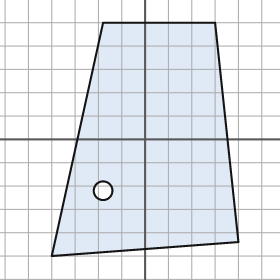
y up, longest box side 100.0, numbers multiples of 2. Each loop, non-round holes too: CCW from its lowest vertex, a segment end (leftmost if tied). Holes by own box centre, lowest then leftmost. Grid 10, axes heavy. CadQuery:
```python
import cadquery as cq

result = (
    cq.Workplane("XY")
    .moveTo(-40.0, -50.0)
    .lineTo(40.0, -44.0)
    .lineTo(30.0, 50.0)
    .lineTo(-18.0, 50.0)
    .close()
    .moveTo(-18.0, -22.0)
    .circle(4.0)
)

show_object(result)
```